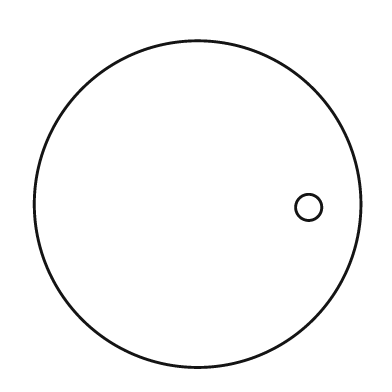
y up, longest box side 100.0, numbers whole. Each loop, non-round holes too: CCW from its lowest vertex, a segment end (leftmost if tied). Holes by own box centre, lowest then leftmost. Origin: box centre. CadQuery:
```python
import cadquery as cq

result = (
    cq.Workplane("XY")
    .moveTo(0.0, 0.0)
    .circle(50.0)
    .moveTo(34.0, -1.0)
    .circle(4.0)
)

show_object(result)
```